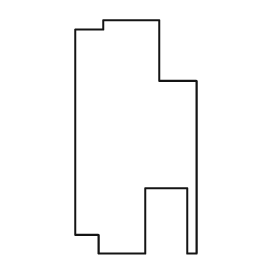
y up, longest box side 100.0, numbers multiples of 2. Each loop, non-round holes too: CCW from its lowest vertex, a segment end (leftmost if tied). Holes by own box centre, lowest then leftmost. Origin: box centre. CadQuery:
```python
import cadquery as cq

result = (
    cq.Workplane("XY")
    .moveTo(-16.0, -50.0)
    .lineTo(4.0, -50.0)
    .lineTo(4.0, -22.0)
    .lineTo(22.0, -22.0)
    .lineTo(22.0, -50.0)
    .lineTo(26.0, -50.0)
    .lineTo(26.0, 24.0)
    .lineTo(10.0, 24.0)
    .lineTo(10.0, 50.0)
    .lineTo(-14.0, 50.0)
    .lineTo(-14.0, 46.0)
    .lineTo(-26.0, 46.0)
    .lineTo(-26.0, -42.0)
    .lineTo(-16.0, -42.0)
    .close()
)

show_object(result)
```